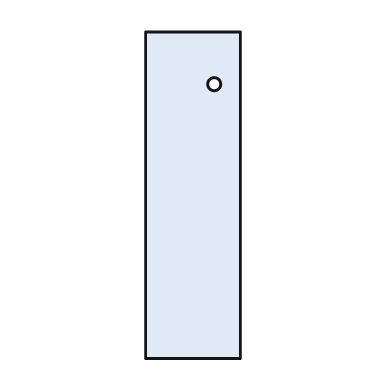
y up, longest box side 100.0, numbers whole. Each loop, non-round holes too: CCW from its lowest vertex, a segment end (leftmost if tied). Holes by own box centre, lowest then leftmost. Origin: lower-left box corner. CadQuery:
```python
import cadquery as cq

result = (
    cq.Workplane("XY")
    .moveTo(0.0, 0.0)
    .lineTo(29.0, 0.0)
    .lineTo(29.0, 100.0)
    .lineTo(0.0, 100.0)
    .close()
    .moveTo(21.0, 84.0)
    .circle(2.0)
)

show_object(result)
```